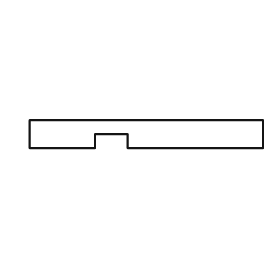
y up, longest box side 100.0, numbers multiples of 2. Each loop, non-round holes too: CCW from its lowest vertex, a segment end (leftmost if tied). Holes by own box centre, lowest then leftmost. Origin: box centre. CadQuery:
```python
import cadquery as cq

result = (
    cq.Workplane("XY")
    .moveTo(-50.0, -6.0)
    .lineTo(-22.0, -6.0)
    .lineTo(-22.0, 0.0)
    .lineTo(-8.0, 0.0)
    .lineTo(-8.0, -6.0)
    .lineTo(50.0, -6.0)
    .lineTo(50.0, 6.0)
    .lineTo(-50.0, 6.0)
    .close()
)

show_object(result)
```